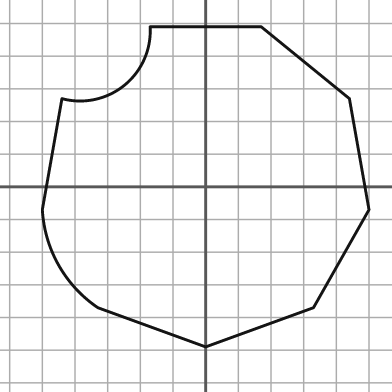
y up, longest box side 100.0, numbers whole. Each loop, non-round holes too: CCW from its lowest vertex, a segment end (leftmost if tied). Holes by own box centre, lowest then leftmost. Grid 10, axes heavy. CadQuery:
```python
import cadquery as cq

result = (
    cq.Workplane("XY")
    .moveTo(0.0, -49.0)
    .lineTo(33.0, -37.0)
    .lineTo(50.0, -7.0)
    .lineTo(44.0, 27.0)
    .lineTo(17.0, 49.0)
    .lineTo(-17.0, 49.0)
    .threePointArc((-25.0, 31.0), (-44.0, 27.0))
    .lineTo(-50.0, -7.0)
    .threePointArc((-45.0, -24.0), (-33.0, -37.0))
    .close()
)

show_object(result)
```